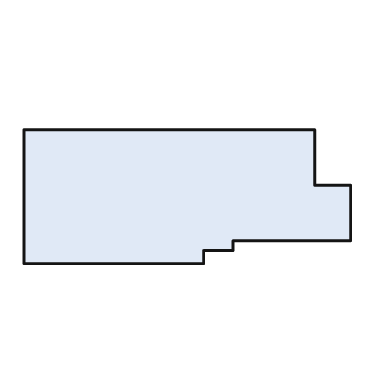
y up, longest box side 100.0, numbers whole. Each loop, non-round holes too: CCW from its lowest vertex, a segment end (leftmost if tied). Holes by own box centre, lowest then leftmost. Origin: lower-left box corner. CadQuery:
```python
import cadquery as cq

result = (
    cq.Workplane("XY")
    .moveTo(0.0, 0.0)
    .lineTo(55.0, 0.0)
    .lineTo(55.0, 4.0)
    .lineTo(64.0, 4.0)
    .lineTo(64.0, 7.0)
    .lineTo(100.0, 7.0)
    .lineTo(100.0, 24.0)
    .lineTo(89.0, 24.0)
    .lineTo(89.0, 41.0)
    .lineTo(0.0, 41.0)
    .close()
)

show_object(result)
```